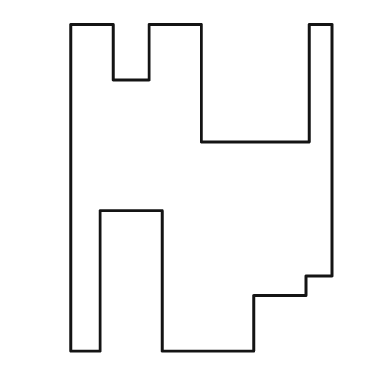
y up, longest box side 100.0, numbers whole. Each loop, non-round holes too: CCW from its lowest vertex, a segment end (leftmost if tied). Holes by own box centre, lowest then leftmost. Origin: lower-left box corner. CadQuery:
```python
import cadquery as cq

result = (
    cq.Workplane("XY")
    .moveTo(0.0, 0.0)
    .lineTo(9.0, 0.0)
    .lineTo(9.0, 43.0)
    .lineTo(28.0, 43.0)
    .lineTo(28.0, 0.0)
    .lineTo(56.0, 0.0)
    .lineTo(56.0, 17.0)
    .lineTo(72.0, 17.0)
    .lineTo(72.0, 23.0)
    .lineTo(80.0, 23.0)
    .lineTo(80.0, 100.0)
    .lineTo(73.0, 100.0)
    .lineTo(73.0, 64.0)
    .lineTo(40.0, 64.0)
    .lineTo(40.0, 100.0)
    .lineTo(24.0, 100.0)
    .lineTo(24.0, 83.0)
    .lineTo(13.0, 83.0)
    .lineTo(13.0, 100.0)
    .lineTo(0.0, 100.0)
    .close()
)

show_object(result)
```